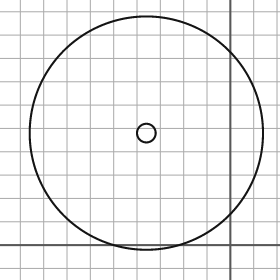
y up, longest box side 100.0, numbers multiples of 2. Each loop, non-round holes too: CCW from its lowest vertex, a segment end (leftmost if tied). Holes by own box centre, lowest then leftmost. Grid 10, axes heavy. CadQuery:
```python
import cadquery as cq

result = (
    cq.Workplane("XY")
    .moveTo(-36.0, 48.0)
    .circle(50.0)
    .moveTo(-36.0, 48.0)
    .circle(4.0)
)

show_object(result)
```